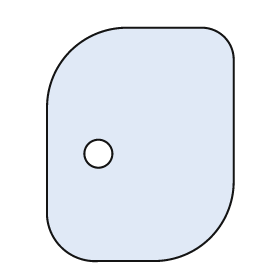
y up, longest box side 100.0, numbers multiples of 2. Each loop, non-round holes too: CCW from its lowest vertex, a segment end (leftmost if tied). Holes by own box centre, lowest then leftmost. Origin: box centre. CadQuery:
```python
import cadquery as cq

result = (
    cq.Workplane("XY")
    .moveTo(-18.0, -50.0)
    .lineTo(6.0, -50.0)
    .threePointArc((30.0, -40.0), (40.0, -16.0))
    .lineTo(40.0, 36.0)
    .threePointArc((36.0, 46.0), (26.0, 50.0))
    .lineTo(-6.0, 50.0)
    .threePointArc((-30.0, 40.0), (-40.0, 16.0))
    .lineTo(-40.0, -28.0)
    .threePointArc((-34.0, -44.0), (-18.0, -50.0))
    .close()
    .moveTo(-18.0, -4.0)
    .circle(6.0)
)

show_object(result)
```